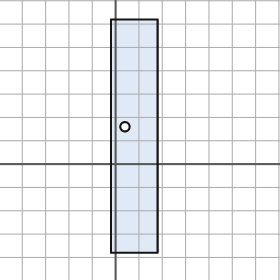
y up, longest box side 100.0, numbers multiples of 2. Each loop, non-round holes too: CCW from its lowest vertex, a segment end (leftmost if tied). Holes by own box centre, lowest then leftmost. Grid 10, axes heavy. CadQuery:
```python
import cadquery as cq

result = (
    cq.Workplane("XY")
    .moveTo(-2.0, -38.0)
    .lineTo(18.0, -38.0)
    .lineTo(18.0, 62.0)
    .lineTo(-2.0, 62.0)
    .close()
    .moveTo(4.0, 16.0)
    .circle(2.0)
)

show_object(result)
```